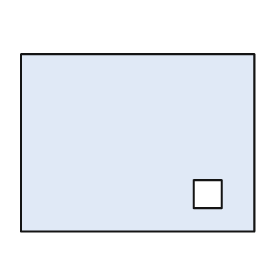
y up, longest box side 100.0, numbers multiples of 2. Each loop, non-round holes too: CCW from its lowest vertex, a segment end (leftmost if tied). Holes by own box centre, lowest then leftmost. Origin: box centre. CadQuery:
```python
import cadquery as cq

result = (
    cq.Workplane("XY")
    .moveTo(-50.0, -38.0)
    .lineTo(50.0, -38.0)
    .lineTo(50.0, 38.0)
    .lineTo(-50.0, 38.0)
    .close()
    .moveTo(24.0, -28.0)
    .lineTo(36.0, -28.0)
    .lineTo(36.0, -16.0)
    .lineTo(24.0, -16.0)
    .close()
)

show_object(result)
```